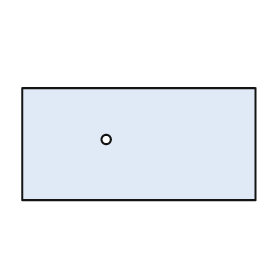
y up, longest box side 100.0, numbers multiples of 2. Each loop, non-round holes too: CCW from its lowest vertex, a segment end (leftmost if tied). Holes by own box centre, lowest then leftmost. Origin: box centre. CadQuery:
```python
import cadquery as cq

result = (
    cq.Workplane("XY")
    .moveTo(-50.0, -24.0)
    .lineTo(50.0, -24.0)
    .lineTo(50.0, 24.0)
    .lineTo(-50.0, 24.0)
    .close()
    .moveTo(-14.0, 2.0)
    .circle(2.0)
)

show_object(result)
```